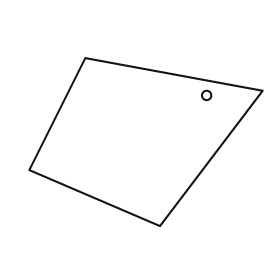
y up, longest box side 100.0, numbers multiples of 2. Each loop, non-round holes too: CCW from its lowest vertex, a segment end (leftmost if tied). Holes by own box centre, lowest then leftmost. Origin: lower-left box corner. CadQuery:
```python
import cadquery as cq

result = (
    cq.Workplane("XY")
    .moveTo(56.0, 0.0)
    .lineTo(100.0, 58.0)
    .lineTo(24.0, 72.0)
    .lineTo(0.0, 24.0)
    .close()
    .moveTo(76.0, 56.0)
    .circle(2.0)
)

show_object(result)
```